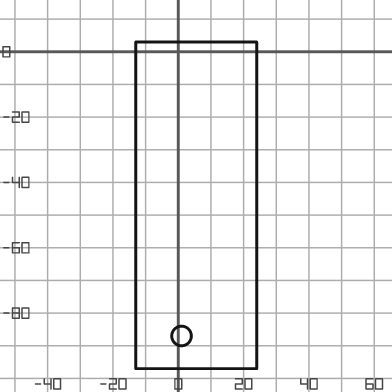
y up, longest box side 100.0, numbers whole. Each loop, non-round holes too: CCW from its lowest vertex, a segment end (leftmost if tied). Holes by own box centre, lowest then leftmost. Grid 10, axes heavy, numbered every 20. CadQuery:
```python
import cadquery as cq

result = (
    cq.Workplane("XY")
    .moveTo(-13.0, -97.0)
    .lineTo(24.0, -97.0)
    .lineTo(24.0, 3.0)
    .lineTo(-13.0, 3.0)
    .close()
    .moveTo(1.0, -87.0)
    .circle(3.0)
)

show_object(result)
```